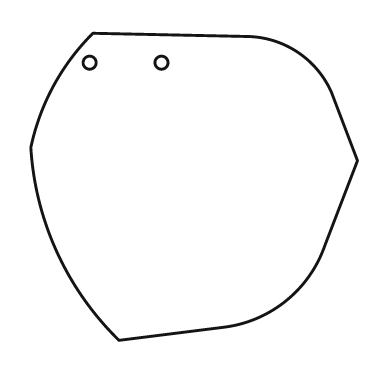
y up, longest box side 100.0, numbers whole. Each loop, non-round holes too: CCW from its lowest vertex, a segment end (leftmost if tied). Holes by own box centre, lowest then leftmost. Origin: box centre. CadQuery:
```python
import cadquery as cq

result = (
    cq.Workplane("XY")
    .moveTo(-23.0, -47.0)
    .lineTo(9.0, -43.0)
    .threePointArc((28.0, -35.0), (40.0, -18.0))
    .lineTo(50.0, 8.0)
    .lineTo(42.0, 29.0)
    .threePointArc((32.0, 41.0), (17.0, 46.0))
    .lineTo(-31.0, 47.0)
    .threePointArc((-43.0, 31.0), (-50.0, 12.0))
    .threePointArc((-42.0, -20.0), (-23.0, -47.0))
    .close()
    .moveTo(-32.0, 38.0)
    .circle(2.0)
    .moveTo(-10.0, 38.0)
    .circle(2.0)
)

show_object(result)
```